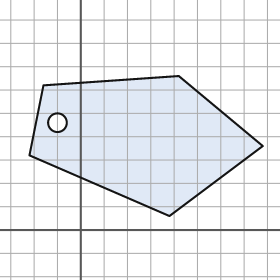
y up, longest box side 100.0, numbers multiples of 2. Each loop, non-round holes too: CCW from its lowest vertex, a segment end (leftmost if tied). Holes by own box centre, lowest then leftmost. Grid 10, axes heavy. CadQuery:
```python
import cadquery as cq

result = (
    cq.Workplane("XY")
    .moveTo(38.0, 6.0)
    .lineTo(78.0, 36.0)
    .lineTo(42.0, 66.0)
    .lineTo(-16.0, 62.0)
    .lineTo(-22.0, 32.0)
    .close()
    .moveTo(-10.0, 46.0)
    .circle(4.0)
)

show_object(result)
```